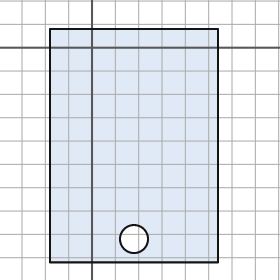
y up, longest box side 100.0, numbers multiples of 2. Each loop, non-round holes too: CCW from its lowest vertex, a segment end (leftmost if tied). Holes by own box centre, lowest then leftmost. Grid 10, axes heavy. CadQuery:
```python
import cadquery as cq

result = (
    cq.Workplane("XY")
    .moveTo(-18.0, -92.0)
    .lineTo(54.0, -92.0)
    .lineTo(54.0, 8.0)
    .lineTo(-18.0, 8.0)
    .close()
    .moveTo(18.0, -82.0)
    .circle(6.0)
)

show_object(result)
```